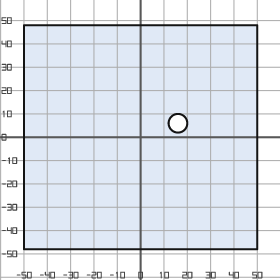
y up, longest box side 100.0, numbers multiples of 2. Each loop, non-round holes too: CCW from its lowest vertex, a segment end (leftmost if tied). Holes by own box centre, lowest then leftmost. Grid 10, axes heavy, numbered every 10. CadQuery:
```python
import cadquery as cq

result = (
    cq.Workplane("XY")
    .moveTo(-50.0, -48.0)
    .lineTo(50.0, -48.0)
    .lineTo(50.0, 48.0)
    .lineTo(-50.0, 48.0)
    .close()
    .moveTo(16.0, 6.0)
    .circle(4.0)
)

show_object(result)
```